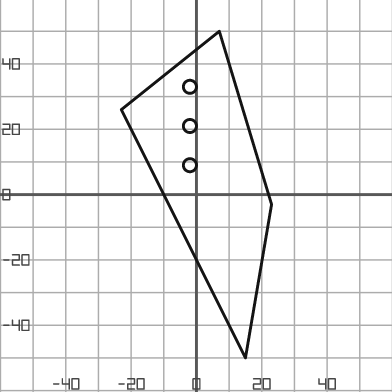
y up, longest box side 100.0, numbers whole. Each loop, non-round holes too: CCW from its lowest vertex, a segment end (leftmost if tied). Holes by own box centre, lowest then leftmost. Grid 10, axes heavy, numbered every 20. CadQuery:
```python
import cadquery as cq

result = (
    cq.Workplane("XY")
    .moveTo(15.0, -50.0)
    .lineTo(23.0, -3.0)
    .lineTo(7.0, 50.0)
    .lineTo(-23.0, 26.0)
    .close()
    .moveTo(-2.0, 9.0)
    .circle(2.0)
    .moveTo(-2.0, 21.0)
    .circle(2.0)
    .moveTo(-2.0, 33.0)
    .circle(2.0)
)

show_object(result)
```